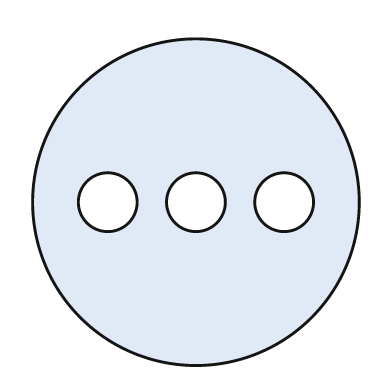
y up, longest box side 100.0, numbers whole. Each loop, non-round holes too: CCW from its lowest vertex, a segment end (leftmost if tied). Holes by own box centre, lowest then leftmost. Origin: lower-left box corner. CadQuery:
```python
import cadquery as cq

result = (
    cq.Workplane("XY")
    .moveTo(50.0, 50.0)
    .circle(50.0)
    .moveTo(23.0, 50.0)
    .circle(9.0)
    .moveTo(50.0, 50.0)
    .circle(9.0)
    .moveTo(77.0, 50.0)
    .circle(9.0)
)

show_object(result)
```